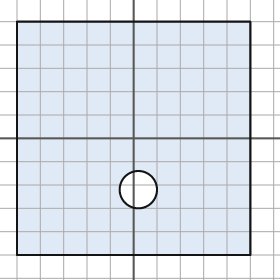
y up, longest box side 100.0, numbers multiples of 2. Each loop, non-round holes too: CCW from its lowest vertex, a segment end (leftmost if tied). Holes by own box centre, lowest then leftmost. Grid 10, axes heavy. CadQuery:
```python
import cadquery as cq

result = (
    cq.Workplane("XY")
    .moveTo(-50.0, -50.0)
    .lineTo(50.0, -50.0)
    .lineTo(50.0, 50.0)
    .lineTo(-50.0, 50.0)
    .close()
    .moveTo(2.0, -22.0)
    .circle(8.0)
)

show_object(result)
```